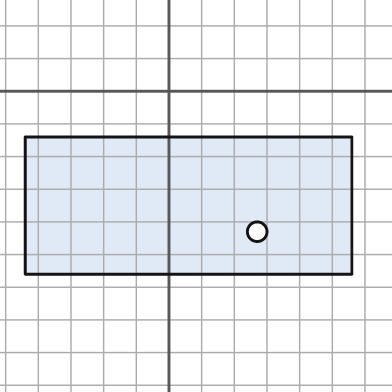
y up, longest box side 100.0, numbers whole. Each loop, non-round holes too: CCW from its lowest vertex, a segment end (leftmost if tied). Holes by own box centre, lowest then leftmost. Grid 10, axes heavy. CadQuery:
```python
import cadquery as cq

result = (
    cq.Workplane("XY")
    .moveTo(-44.0, -56.0)
    .lineTo(56.0, -56.0)
    .lineTo(56.0, -14.0)
    .lineTo(-44.0, -14.0)
    .close()
    .moveTo(27.0, -43.0)
    .circle(3.0)
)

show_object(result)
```